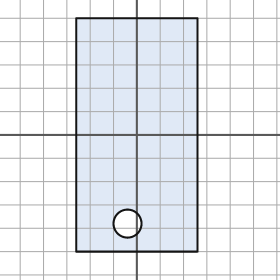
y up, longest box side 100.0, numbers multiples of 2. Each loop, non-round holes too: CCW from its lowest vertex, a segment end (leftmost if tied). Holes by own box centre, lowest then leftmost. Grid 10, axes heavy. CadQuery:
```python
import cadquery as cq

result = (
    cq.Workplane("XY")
    .moveTo(-26.0, -50.0)
    .lineTo(26.0, -50.0)
    .lineTo(26.0, 50.0)
    .lineTo(-26.0, 50.0)
    .close()
    .moveTo(-4.0, -38.0)
    .circle(6.0)
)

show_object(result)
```